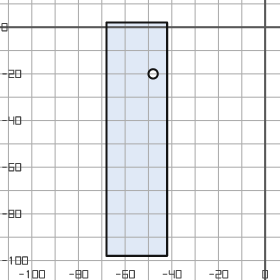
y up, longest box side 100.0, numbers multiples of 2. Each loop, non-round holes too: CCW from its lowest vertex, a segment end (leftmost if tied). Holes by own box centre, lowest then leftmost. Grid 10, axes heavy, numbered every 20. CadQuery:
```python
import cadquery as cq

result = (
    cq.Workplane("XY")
    .moveTo(-68.0, -98.0)
    .lineTo(-42.0, -98.0)
    .lineTo(-42.0, 2.0)
    .lineTo(-68.0, 2.0)
    .close()
    .moveTo(-48.0, -20.0)
    .circle(2.0)
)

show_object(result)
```